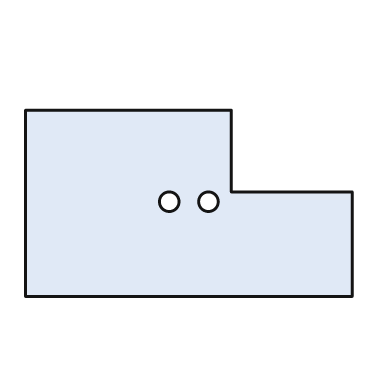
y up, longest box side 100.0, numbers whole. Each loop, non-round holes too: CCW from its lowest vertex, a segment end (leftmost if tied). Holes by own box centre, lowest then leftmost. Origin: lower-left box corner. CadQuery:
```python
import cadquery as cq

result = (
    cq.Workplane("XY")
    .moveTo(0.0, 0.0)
    .lineTo(100.0, 0.0)
    .lineTo(100.0, 32.0)
    .lineTo(63.0, 32.0)
    .lineTo(63.0, 57.0)
    .lineTo(0.0, 57.0)
    .close()
    .moveTo(44.0, 29.0)
    .circle(3.0)
    .moveTo(56.0, 29.0)
    .circle(3.0)
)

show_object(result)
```